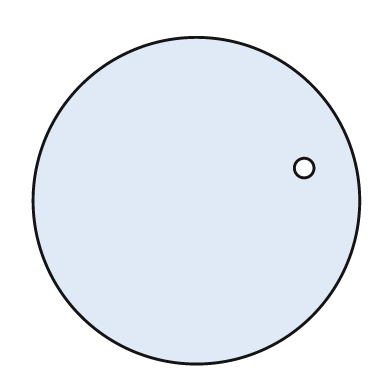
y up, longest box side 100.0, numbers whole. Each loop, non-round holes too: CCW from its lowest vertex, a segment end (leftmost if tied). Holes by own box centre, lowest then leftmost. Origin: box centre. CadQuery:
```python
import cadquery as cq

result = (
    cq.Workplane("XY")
    .moveTo(0.0, 0.0)
    .circle(50.0)
    .moveTo(33.0, 10.0)
    .circle(3.0)
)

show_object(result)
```